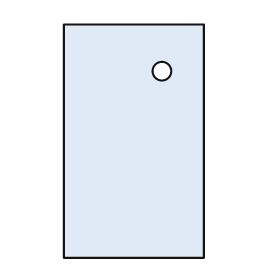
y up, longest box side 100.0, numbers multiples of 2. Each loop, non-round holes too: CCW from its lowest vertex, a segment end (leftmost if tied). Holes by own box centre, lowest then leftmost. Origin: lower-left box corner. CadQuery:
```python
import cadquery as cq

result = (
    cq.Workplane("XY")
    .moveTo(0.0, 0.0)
    .lineTo(60.0, 0.0)
    .lineTo(60.0, 100.0)
    .lineTo(0.0, 100.0)
    .close()
    .moveTo(42.0, 80.0)
    .circle(4.0)
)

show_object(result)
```